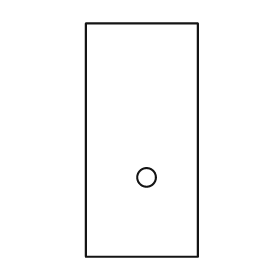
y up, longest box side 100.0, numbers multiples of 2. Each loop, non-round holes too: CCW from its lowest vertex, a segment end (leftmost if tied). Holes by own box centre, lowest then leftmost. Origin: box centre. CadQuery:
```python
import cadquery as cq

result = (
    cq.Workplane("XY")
    .moveTo(-24.0, -50.0)
    .lineTo(24.0, -50.0)
    .lineTo(24.0, 50.0)
    .lineTo(-24.0, 50.0)
    .close()
    .moveTo(2.0, -16.0)
    .circle(4.0)
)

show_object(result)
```